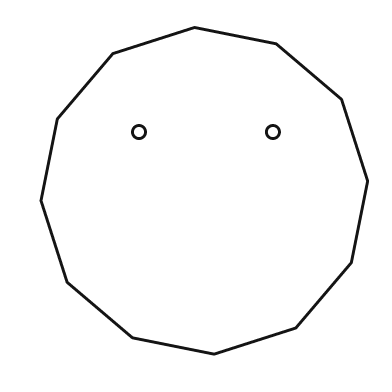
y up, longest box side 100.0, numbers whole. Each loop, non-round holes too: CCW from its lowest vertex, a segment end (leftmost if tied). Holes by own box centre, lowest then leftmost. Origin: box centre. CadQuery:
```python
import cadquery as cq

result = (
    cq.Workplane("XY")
    .moveTo(3.0, -50.0)
    .lineTo(28.0, -42.0)
    .lineTo(45.0, -22.0)
    .lineTo(50.0, 3.0)
    .lineTo(42.0, 28.0)
    .lineTo(22.0, 45.0)
    .lineTo(-3.0, 50.0)
    .lineTo(-28.0, 42.0)
    .lineTo(-45.0, 22.0)
    .lineTo(-50.0, -3.0)
    .lineTo(-42.0, -28.0)
    .lineTo(-22.0, -45.0)
    .close()
    .moveTo(-20.0, 18.0)
    .circle(2.0)
    .moveTo(21.0, 18.0)
    .circle(2.0)
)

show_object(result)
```